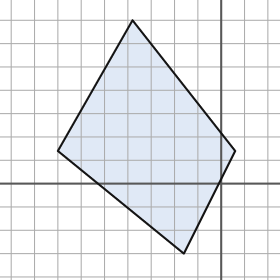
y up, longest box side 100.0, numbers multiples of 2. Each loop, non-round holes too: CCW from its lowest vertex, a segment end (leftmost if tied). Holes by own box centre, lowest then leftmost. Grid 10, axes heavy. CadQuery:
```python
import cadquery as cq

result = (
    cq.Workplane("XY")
    .moveTo(-16.0, -30.0)
    .lineTo(6.0, 14.0)
    .lineTo(-38.0, 70.0)
    .lineTo(-70.0, 14.0)
    .close()
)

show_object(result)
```